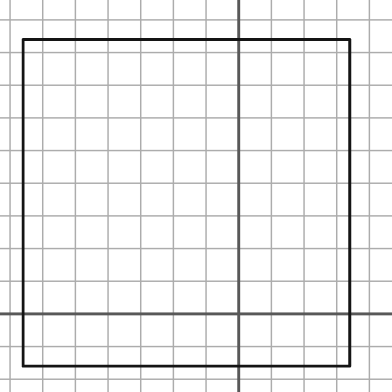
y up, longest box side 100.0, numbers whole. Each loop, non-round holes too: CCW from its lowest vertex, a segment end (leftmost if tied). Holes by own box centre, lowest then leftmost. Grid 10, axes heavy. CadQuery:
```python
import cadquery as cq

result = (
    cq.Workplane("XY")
    .moveTo(-66.0, -16.0)
    .lineTo(34.0, -16.0)
    .lineTo(34.0, 84.0)
    .lineTo(-66.0, 84.0)
    .close()
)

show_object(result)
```